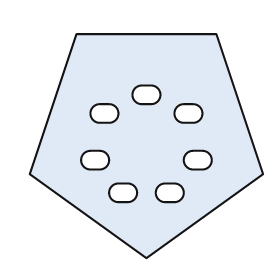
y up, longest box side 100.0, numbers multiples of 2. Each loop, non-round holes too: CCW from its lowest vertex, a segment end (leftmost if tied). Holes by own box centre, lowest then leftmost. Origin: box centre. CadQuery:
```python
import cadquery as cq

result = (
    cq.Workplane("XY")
    .moveTo(0.0, -48.0)
    .lineTo(50.0, -12.0)
    .lineTo(30.0, 48.0)
    .lineTo(-30.0, 48.0)
    .lineTo(-50.0, -12.0)
    .close()
    .moveTo(-12.0, -24.0)
    .lineTo(-8.0, -24.0)
    .threePointArc((-4.0, -20.0), (-8.0, -16.0))
    .lineTo(-12.0, -16.0)
    .threePointArc((-16.0, -20.0), (-12.0, -24.0))
    .close()
    .moveTo(8.0, -24.0)
    .lineTo(12.0, -24.0)
    .threePointArc((16.0, -20.0), (12.0, -16.0))
    .lineTo(8.0, -16.0)
    .threePointArc((4.0, -20.0), (8.0, -24.0))
    .close()
    .moveTo(-24.0, -10.0)
    .lineTo(-20.0, -10.0)
    .threePointArc((-16.0, -6.0), (-20.0, -2.0))
    .lineTo(-24.0, -2.0)
    .threePointArc((-28.0, -6.0), (-24.0, -10.0))
    .close()
    .moveTo(20.0, -10.0)
    .lineTo(24.0, -10.0)
    .threePointArc((28.0, -6.0), (24.0, -2.0))
    .lineTo(20.0, -2.0)
    .threePointArc((16.0, -6.0), (20.0, -10.0))
    .close()
    .moveTo(-20.0, 10.0)
    .lineTo(-16.0, 10.0)
    .threePointArc((-12.0, 14.0), (-16.0, 18.0))
    .lineTo(-20.0, 18.0)
    .threePointArc((-24.0, 14.0), (-20.0, 10.0))
    .close()
    .moveTo(16.0, 10.0)
    .lineTo(20.0, 10.0)
    .threePointArc((24.0, 14.0), (20.0, 18.0))
    .lineTo(16.0, 18.0)
    .threePointArc((12.0, 14.0), (16.0, 10.0))
    .close()
    .moveTo(-2.0, 18.0)
    .lineTo(2.0, 18.0)
    .threePointArc((6.0, 22.0), (2.0, 26.0))
    .lineTo(-2.0, 26.0)
    .threePointArc((-6.0, 22.0), (-2.0, 18.0))
    .close()
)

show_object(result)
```